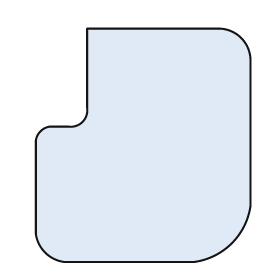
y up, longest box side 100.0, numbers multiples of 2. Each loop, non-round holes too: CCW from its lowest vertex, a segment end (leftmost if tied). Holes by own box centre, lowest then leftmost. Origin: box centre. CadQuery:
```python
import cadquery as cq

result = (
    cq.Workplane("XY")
    .moveTo(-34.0, -50.0)
    .lineTo(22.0, -50.0)
    .threePointArc((38.0, -42.0), (46.0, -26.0))
    .lineTo(46.0, 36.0)
    .threePointArc((42.0, 46.0), (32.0, 50.0))
    .lineTo(-24.0, 50.0)
    .lineTo(-24.0, 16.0)
    .threePointArc((-26.0, 10.0), (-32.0, 8.0))
    .lineTo(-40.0, 8.0)
    .threePointArc((-44.0, 6.0), (-46.0, 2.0))
    .lineTo(-46.0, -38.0)
    .threePointArc((-42.0, -46.0), (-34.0, -50.0))
    .close()
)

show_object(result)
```